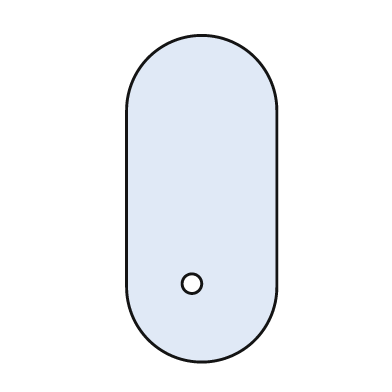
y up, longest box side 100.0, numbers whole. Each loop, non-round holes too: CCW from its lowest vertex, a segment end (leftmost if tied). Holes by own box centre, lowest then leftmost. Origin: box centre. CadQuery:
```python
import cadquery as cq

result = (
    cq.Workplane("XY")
    .moveTo(-23.0, -27.0)
    .threePointArc((0.0, -50.0), (23.0, -27.0))
    .lineTo(23.0, 27.0)
    .threePointArc((0.0, 50.0), (-23.0, 27.0))
    .close()
    .moveTo(-3.0, -26.0)
    .circle(3.0)
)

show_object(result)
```